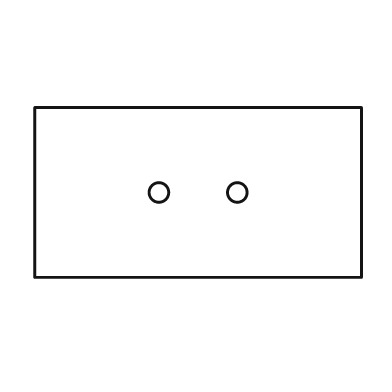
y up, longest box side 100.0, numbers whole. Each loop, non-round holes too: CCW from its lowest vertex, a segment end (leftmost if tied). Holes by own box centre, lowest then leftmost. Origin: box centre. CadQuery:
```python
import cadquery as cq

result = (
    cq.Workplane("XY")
    .moveTo(-50.0, -26.0)
    .lineTo(50.0, -26.0)
    .lineTo(50.0, 26.0)
    .lineTo(-50.0, 26.0)
    .close()
    .moveTo(-12.0, 0.0)
    .circle(3.0)
    .moveTo(12.0, 0.0)
    .circle(3.0)
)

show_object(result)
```